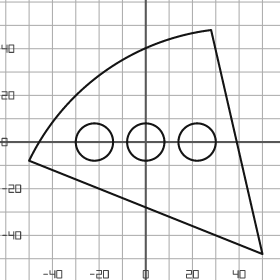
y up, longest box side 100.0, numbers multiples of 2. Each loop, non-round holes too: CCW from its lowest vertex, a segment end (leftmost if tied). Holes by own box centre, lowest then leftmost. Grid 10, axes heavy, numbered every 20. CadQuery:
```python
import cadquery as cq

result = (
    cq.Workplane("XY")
    .moveTo(50.0, -48.0)
    .lineTo(28.0, 48.0)
    .threePointArc((-18.0, 30.0), (-50.0, -8.0))
    .close()
    .moveTo(-22.0, 0.0)
    .circle(8.0)
    .moveTo(0.0, 0.0)
    .circle(8.0)
    .moveTo(22.0, 0.0)
    .circle(8.0)
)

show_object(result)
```